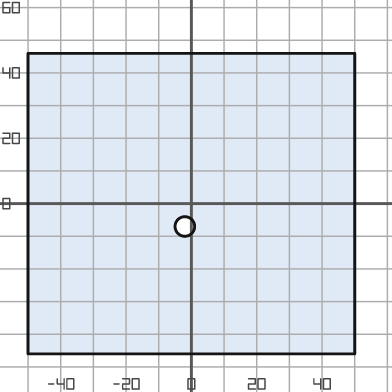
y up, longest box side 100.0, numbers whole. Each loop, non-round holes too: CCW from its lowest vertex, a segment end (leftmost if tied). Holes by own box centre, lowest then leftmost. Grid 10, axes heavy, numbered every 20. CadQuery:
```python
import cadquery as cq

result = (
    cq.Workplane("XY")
    .moveTo(-50.0, -46.0)
    .lineTo(50.0, -46.0)
    .lineTo(50.0, 46.0)
    .lineTo(-50.0, 46.0)
    .close()
    .moveTo(-2.0, -7.0)
    .circle(3.0)
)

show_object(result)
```